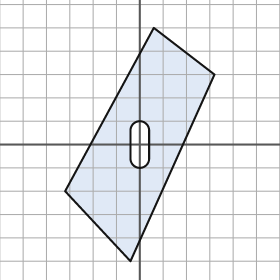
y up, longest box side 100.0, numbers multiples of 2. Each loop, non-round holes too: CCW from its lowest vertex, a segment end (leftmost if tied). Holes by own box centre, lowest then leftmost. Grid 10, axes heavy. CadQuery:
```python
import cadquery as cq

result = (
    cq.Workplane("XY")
    .moveTo(-4.0, -50.0)
    .lineTo(32.0, 30.0)
    .lineTo(6.0, 50.0)
    .lineTo(-32.0, -20.0)
    .close()
    .moveTo(-4.0, -6.0)
    .threePointArc((0.0, -10.0), (4.0, -6.0))
    .lineTo(4.0, 6.0)
    .threePointArc((0.0, 10.0), (-4.0, 6.0))
    .close()
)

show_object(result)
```